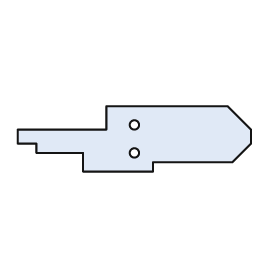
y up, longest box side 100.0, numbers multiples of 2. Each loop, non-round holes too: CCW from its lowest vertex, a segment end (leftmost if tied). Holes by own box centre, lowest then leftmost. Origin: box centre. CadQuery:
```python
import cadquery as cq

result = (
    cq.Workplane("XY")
    .moveTo(-22.0, -14.0)
    .lineTo(8.0, -14.0)
    .lineTo(8.0, -10.0)
    .lineTo(42.0, -10.0)
    .lineTo(50.0, -2.0)
    .lineTo(50.0, 4.0)
    .lineTo(40.0, 14.0)
    .lineTo(-12.0, 14.0)
    .lineTo(-12.0, 4.0)
    .lineTo(-50.0, 4.0)
    .lineTo(-50.0, -2.0)
    .lineTo(-42.0, -2.0)
    .lineTo(-42.0, -6.0)
    .lineTo(-22.0, -6.0)
    .close()
    .moveTo(0.0, -6.0)
    .circle(2.0)
    .moveTo(0.0, 6.0)
    .circle(2.0)
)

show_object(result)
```